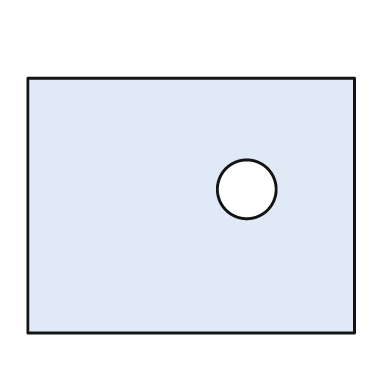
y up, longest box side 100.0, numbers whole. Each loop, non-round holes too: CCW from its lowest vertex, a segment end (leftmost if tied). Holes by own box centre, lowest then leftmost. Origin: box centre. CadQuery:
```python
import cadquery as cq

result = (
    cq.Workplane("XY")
    .moveTo(-50.0, -39.0)
    .lineTo(50.0, -39.0)
    .lineTo(50.0, 39.0)
    .lineTo(-50.0, 39.0)
    .close()
    .moveTo(17.0, 5.0)
    .circle(9.0)
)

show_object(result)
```